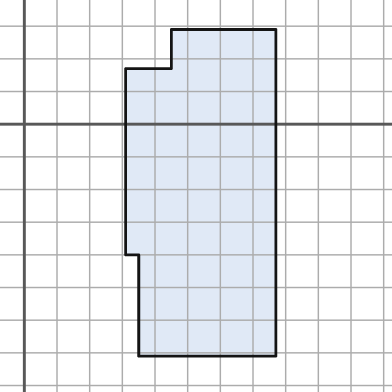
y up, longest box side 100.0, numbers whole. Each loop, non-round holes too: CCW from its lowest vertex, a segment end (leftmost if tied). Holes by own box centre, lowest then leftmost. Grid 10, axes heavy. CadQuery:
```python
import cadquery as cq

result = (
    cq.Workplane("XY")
    .moveTo(35.0, -71.0)
    .lineTo(77.0, -71.0)
    .lineTo(77.0, 29.0)
    .lineTo(45.0, 29.0)
    .lineTo(45.0, 17.0)
    .lineTo(31.0, 17.0)
    .lineTo(31.0, -40.0)
    .lineTo(35.0, -40.0)
    .close()
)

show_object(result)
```